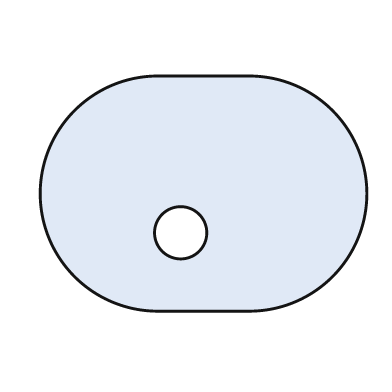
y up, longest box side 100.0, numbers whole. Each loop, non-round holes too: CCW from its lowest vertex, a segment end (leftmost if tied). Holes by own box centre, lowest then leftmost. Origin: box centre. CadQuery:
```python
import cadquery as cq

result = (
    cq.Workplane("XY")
    .moveTo(-14.0, -36.0)
    .lineTo(14.0, -36.0)
    .threePointArc((50.0, 0.0), (14.0, 36.0))
    .lineTo(-14.0, 36.0)
    .threePointArc((-50.0, 0.0), (-14.0, -36.0))
    .close()
    .moveTo(-7.0, -12.0)
    .circle(8.0)
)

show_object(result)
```